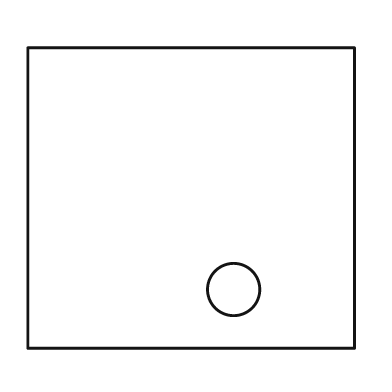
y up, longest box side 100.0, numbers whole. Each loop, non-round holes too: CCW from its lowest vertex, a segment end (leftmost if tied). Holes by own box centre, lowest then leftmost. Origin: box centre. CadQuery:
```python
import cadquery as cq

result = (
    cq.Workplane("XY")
    .moveTo(-50.0, -46.0)
    .lineTo(50.0, -46.0)
    .lineTo(50.0, 46.0)
    .lineTo(-50.0, 46.0)
    .close()
    .moveTo(13.0, -28.0)
    .circle(8.0)
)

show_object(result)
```